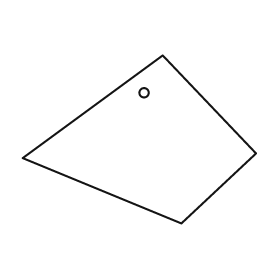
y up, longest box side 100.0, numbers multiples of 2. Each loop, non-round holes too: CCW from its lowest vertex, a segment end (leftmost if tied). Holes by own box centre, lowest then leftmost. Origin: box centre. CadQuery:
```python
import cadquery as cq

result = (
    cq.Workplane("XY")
    .moveTo(18.0, -36.0)
    .lineTo(50.0, -6.0)
    .lineTo(10.0, 36.0)
    .lineTo(-50.0, -8.0)
    .close()
    .moveTo(2.0, 20.0)
    .circle(2.0)
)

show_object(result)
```